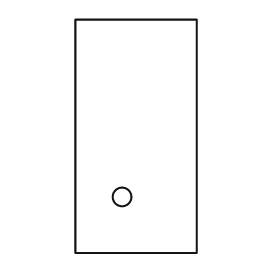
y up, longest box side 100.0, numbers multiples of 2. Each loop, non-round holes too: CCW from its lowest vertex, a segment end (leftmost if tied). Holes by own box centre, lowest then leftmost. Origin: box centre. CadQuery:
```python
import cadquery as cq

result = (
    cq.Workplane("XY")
    .moveTo(-26.0, -50.0)
    .lineTo(26.0, -50.0)
    .lineTo(26.0, 50.0)
    .lineTo(-26.0, 50.0)
    .close()
    .moveTo(-6.0, -26.0)
    .circle(4.0)
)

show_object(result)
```